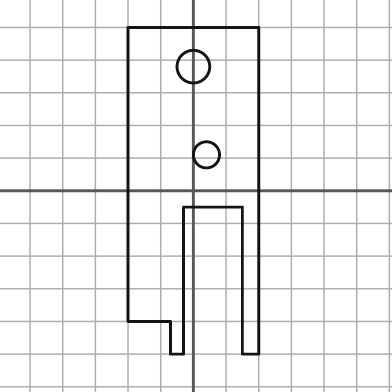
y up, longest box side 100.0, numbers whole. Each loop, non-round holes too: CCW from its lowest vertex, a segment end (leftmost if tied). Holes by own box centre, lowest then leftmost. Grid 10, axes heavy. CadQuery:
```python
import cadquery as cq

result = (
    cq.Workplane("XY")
    .moveTo(-7.0, -50.0)
    .lineTo(-3.0, -50.0)
    .lineTo(-3.0, -5.0)
    .lineTo(15.0, -5.0)
    .lineTo(15.0, -50.0)
    .lineTo(20.0, -50.0)
    .lineTo(20.0, 50.0)
    .lineTo(-20.0, 50.0)
    .lineTo(-20.0, -40.0)
    .lineTo(-7.0, -40.0)
    .close()
    .moveTo(4.0, 11.0)
    .circle(4.0)
    .moveTo(0.0, 38.0)
    .circle(5.0)
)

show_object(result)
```